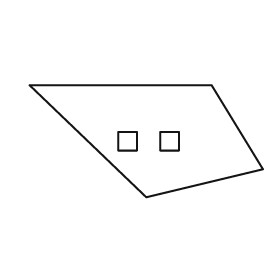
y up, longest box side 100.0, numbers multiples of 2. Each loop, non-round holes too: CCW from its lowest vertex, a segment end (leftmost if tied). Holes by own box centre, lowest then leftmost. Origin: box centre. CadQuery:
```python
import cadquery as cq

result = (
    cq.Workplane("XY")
    .moveTo(0.0, -24.0)
    .lineTo(50.0, -12.0)
    .lineTo(28.0, 24.0)
    .lineTo(-50.0, 24.0)
    .close()
    .moveTo(-12.0, -4.0)
    .lineTo(-4.0, -4.0)
    .lineTo(-4.0, 4.0)
    .lineTo(-12.0, 4.0)
    .close()
    .moveTo(6.0, -4.0)
    .lineTo(14.0, -4.0)
    .lineTo(14.0, 4.0)
    .lineTo(6.0, 4.0)
    .close()
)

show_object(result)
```